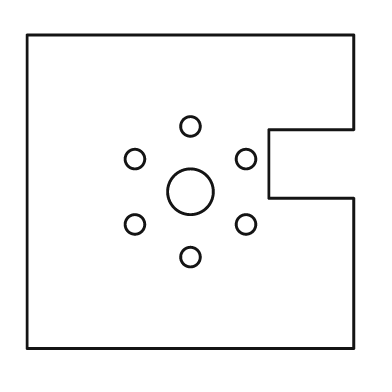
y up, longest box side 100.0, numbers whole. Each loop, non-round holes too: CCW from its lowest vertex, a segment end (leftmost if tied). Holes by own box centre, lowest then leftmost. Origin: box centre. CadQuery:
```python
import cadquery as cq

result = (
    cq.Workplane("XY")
    .moveTo(-50.0, -48.0)
    .lineTo(50.0, -48.0)
    .lineTo(50.0, -2.0)
    .lineTo(24.0, -2.0)
    .lineTo(24.0, 19.0)
    .lineTo(50.0, 19.0)
    .lineTo(50.0, 48.0)
    .lineTo(-50.0, 48.0)
    .close()
    .moveTo(0.0, -20.0)
    .circle(3.0)
    .moveTo(-17.0, -10.0)
    .circle(3.0)
    .moveTo(17.0, -10.0)
    .circle(3.0)
    .moveTo(0.0, 0.0)
    .circle(7.0)
    .moveTo(-17.0, 10.0)
    .circle(3.0)
    .moveTo(17.0, 10.0)
    .circle(3.0)
    .moveTo(0.0, 20.0)
    .circle(3.0)
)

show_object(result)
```